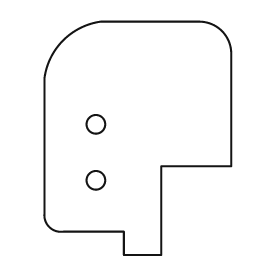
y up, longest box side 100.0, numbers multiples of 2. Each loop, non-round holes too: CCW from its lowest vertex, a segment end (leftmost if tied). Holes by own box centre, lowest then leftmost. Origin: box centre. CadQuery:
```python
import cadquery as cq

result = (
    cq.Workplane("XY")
    .moveTo(-6.0, -50.0)
    .lineTo(10.0, -50.0)
    .lineTo(10.0, -12.0)
    .lineTo(40.0, -12.0)
    .lineTo(40.0, 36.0)
    .threePointArc((36.0, 46.0), (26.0, 50.0))
    .lineTo(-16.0, 50.0)
    .threePointArc((-32.0, 42.0), (-40.0, 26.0))
    .lineTo(-40.0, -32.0)
    .threePointArc((-38.0, -38.0), (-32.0, -40.0))
    .lineTo(-6.0, -40.0)
    .close()
    .moveTo(-18.0, -18.0)
    .circle(4.0)
    .moveTo(-18.0, 6.0)
    .circle(4.0)
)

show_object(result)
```